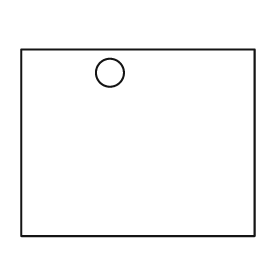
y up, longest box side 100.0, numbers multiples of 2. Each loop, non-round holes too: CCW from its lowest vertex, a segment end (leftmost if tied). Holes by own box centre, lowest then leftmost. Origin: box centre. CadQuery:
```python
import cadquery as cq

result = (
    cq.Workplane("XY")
    .moveTo(-50.0, -40.0)
    .lineTo(50.0, -40.0)
    .lineTo(50.0, 40.0)
    .lineTo(-50.0, 40.0)
    .close()
    .moveTo(-12.0, 30.0)
    .circle(6.0)
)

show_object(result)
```